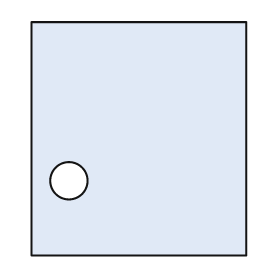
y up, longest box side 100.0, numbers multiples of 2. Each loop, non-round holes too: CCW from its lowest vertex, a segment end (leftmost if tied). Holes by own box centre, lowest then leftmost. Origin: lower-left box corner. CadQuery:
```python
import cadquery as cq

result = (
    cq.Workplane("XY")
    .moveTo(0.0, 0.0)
    .lineTo(92.0, 0.0)
    .lineTo(92.0, 100.0)
    .lineTo(0.0, 100.0)
    .close()
    .moveTo(16.0, 32.0)
    .circle(8.0)
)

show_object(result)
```